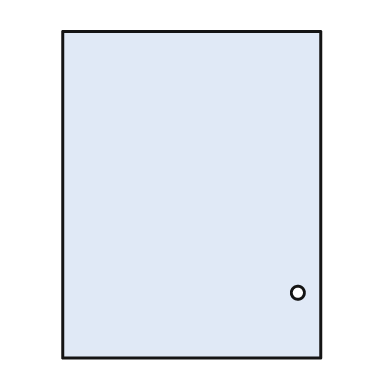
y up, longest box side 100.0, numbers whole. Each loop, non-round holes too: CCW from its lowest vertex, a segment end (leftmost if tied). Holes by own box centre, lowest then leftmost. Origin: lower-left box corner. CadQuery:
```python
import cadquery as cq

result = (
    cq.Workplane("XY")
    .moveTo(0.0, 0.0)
    .lineTo(79.0, 0.0)
    .lineTo(79.0, 100.0)
    .lineTo(0.0, 100.0)
    .close()
    .moveTo(72.0, 20.0)
    .circle(2.0)
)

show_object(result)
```